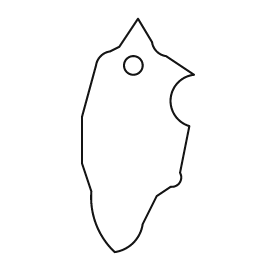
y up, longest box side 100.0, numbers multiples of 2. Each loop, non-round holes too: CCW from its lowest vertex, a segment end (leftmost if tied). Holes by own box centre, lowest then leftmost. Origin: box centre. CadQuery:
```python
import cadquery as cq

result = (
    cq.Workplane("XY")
    .moveTo(-10.0, -50.0)
    .threePointArc((-2.0, -46.0), (2.0, -38.0))
    .lineTo(8.0, -26.0)
    .lineTo(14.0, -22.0)
    .threePointArc((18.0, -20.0), (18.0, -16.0))
    .lineTo(22.0, 4.0)
    .threePointArc((14.0, 16.0), (24.0, 26.0))
    .lineTo(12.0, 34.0)
    .threePointArc((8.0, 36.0), (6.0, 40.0))
    .lineTo(0.0, 50.0)
    .lineTo(-8.0, 38.0)
    .lineTo(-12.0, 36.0)
    .threePointArc((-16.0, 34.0), (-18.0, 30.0))
    .lineTo(-24.0, 8.0)
    .lineTo(-24.0, -12.0)
    .lineTo(-20.0, -24.0)
    .threePointArc((-18.0, -38.0), (-10.0, -50.0))
    .close()
    .moveTo(-2.0, 30.0)
    .circle(4.0)
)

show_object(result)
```